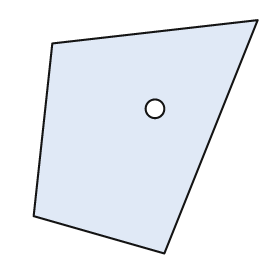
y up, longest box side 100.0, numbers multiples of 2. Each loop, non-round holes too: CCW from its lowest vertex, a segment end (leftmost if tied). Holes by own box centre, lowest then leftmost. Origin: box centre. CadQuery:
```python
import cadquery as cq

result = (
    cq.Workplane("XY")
    .moveTo(8.0, -50.0)
    .lineTo(48.0, 50.0)
    .lineTo(-40.0, 40.0)
    .lineTo(-48.0, -34.0)
    .close()
    .moveTo(4.0, 12.0)
    .circle(4.0)
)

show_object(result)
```